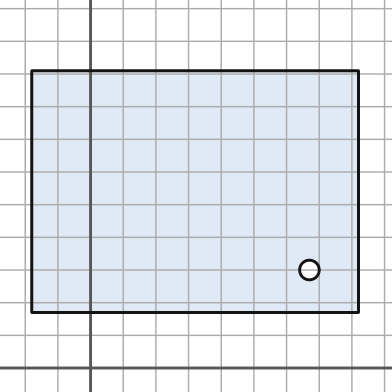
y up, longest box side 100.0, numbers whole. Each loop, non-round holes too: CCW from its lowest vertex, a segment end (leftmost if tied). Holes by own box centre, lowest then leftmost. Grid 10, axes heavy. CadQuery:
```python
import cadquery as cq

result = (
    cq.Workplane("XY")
    .moveTo(-18.0, 17.0)
    .lineTo(82.0, 17.0)
    .lineTo(82.0, 91.0)
    .lineTo(-18.0, 91.0)
    .close()
    .moveTo(67.0, 30.0)
    .circle(3.0)
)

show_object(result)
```